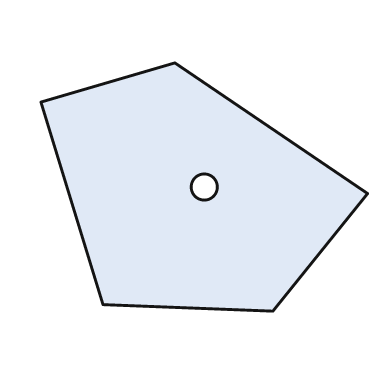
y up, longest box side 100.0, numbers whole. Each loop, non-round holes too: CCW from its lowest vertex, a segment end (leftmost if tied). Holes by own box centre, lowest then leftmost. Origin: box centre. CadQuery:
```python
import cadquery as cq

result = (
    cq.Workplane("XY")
    .moveTo(21.0, -38.0)
    .lineTo(50.0, -2.0)
    .lineTo(-9.0, 38.0)
    .lineTo(-50.0, 26.0)
    .lineTo(-31.0, -36.0)
    .close()
    .moveTo(0.0, 0.0)
    .circle(4.0)
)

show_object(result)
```